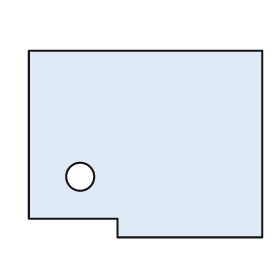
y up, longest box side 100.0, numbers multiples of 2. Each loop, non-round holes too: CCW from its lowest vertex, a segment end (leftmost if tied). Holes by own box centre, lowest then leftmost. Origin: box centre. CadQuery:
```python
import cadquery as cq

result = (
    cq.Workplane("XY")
    .moveTo(-12.0, -40.0)
    .lineTo(50.0, -40.0)
    .lineTo(50.0, 40.0)
    .lineTo(-50.0, 40.0)
    .lineTo(-50.0, -32.0)
    .lineTo(-12.0, -32.0)
    .close()
    .moveTo(-28.0, -14.0)
    .circle(6.0)
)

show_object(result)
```